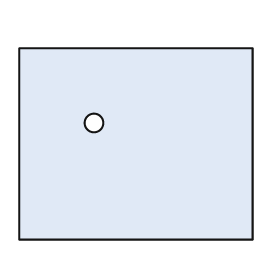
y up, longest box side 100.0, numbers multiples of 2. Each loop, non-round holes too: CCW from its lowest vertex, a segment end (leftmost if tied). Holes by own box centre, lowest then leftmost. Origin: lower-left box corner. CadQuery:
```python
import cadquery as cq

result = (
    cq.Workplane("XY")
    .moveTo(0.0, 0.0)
    .lineTo(100.0, 0.0)
    .lineTo(100.0, 82.0)
    .lineTo(0.0, 82.0)
    .close()
    .moveTo(32.0, 50.0)
    .circle(4.0)
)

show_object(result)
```